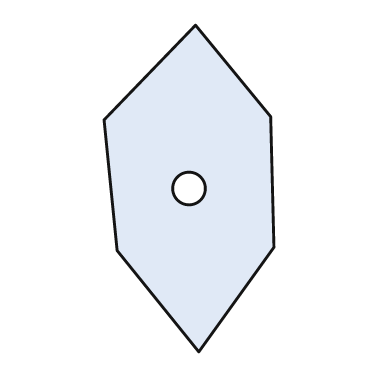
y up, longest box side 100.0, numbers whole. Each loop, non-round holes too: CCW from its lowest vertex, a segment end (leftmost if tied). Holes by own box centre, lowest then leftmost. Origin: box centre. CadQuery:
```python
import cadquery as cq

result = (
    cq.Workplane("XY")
    .moveTo(3.0, -50.0)
    .lineTo(26.0, -18.0)
    .lineTo(25.0, 22.0)
    .lineTo(2.0, 50.0)
    .lineTo(-26.0, 21.0)
    .lineTo(-22.0, -19.0)
    .close()
    .moveTo(0.0, 0.0)
    .circle(5.0)
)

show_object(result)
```